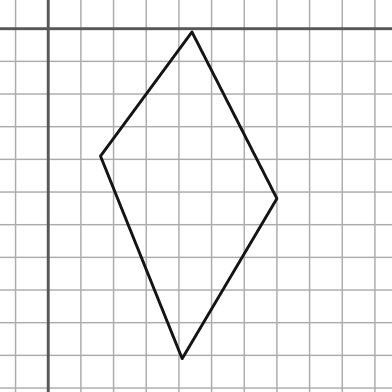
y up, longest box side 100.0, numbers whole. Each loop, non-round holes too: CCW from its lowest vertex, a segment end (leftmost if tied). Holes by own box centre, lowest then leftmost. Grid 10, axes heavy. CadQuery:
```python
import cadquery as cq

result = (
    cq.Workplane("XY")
    .moveTo(41.0, -101.0)
    .lineTo(70.0, -52.0)
    .lineTo(44.0, -1.0)
    .lineTo(16.0, -39.0)
    .close()
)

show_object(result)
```